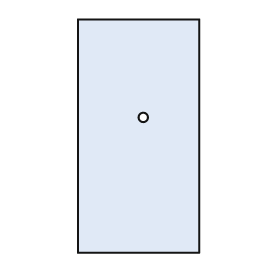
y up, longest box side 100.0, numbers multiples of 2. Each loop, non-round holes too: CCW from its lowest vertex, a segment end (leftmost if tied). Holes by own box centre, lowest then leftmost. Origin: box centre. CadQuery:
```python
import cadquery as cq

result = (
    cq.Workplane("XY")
    .moveTo(-26.0, -50.0)
    .lineTo(26.0, -50.0)
    .lineTo(26.0, 50.0)
    .lineTo(-26.0, 50.0)
    .close()
    .moveTo(2.0, 8.0)
    .circle(2.0)
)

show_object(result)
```